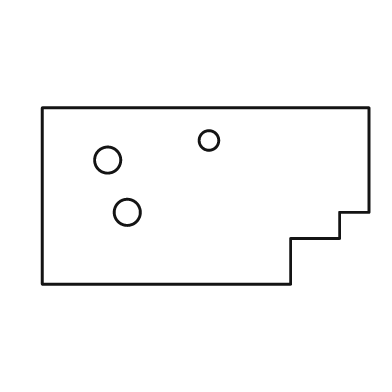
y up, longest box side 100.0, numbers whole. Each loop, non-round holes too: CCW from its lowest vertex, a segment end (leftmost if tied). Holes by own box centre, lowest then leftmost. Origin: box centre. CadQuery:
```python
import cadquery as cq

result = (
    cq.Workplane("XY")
    .moveTo(-50.0, -27.0)
    .lineTo(26.0, -27.0)
    .lineTo(26.0, -13.0)
    .lineTo(41.0, -13.0)
    .lineTo(41.0, -5.0)
    .lineTo(50.0, -5.0)
    .lineTo(50.0, 27.0)
    .lineTo(-50.0, 27.0)
    .close()
    .moveTo(-24.0, -5.0)
    .circle(4.0)
    .moveTo(-30.0, 11.0)
    .circle(4.0)
    .moveTo(1.0, 17.0)
    .circle(3.0)
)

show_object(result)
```